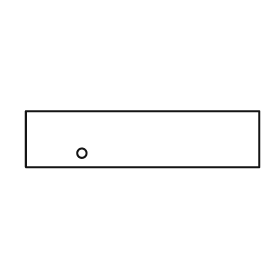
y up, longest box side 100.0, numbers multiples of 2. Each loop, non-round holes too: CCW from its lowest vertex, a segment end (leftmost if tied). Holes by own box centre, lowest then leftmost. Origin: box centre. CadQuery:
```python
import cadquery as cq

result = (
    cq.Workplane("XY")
    .moveTo(-50.0, -12.0)
    .lineTo(50.0, -12.0)
    .lineTo(50.0, 12.0)
    .lineTo(-50.0, 12.0)
    .close()
    .moveTo(-26.0, -6.0)
    .circle(2.0)
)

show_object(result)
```